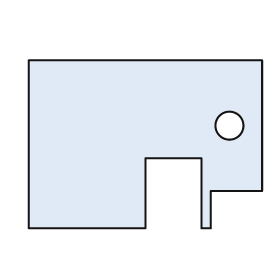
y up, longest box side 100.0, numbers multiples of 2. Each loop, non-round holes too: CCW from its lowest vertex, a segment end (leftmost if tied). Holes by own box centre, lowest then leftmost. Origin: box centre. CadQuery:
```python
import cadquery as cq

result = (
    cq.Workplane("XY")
    .moveTo(-50.0, -36.0)
    .lineTo(0.0, -36.0)
    .lineTo(0.0, -6.0)
    .lineTo(24.0, -6.0)
    .lineTo(24.0, -36.0)
    .lineTo(28.0, -36.0)
    .lineTo(28.0, -20.0)
    .lineTo(50.0, -20.0)
    .lineTo(50.0, 36.0)
    .lineTo(-50.0, 36.0)
    .close()
    .moveTo(36.0, 8.0)
    .circle(6.0)
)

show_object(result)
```